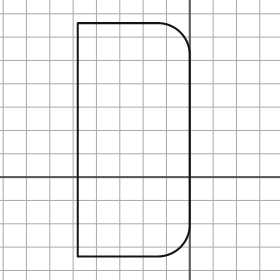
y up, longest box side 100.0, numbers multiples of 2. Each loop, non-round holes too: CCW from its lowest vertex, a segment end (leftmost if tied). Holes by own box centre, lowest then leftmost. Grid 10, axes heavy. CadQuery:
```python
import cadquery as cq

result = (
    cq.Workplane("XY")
    .moveTo(-48.0, -34.0)
    .lineTo(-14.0, -34.0)
    .threePointArc((-4.0, -30.0), (0.0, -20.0))
    .lineTo(0.0, 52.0)
    .threePointArc((-4.0, 62.0), (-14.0, 66.0))
    .lineTo(-48.0, 66.0)
    .close()
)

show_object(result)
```